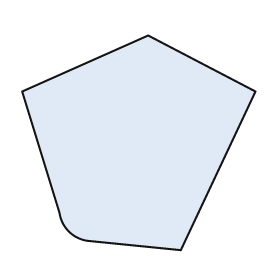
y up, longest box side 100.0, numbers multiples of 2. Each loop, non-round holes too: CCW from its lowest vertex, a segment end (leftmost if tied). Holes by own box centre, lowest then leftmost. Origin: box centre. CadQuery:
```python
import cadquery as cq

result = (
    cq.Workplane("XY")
    .moveTo(18.0, -46.0)
    .lineTo(50.0, 22.0)
    .lineTo(4.0, 46.0)
    .lineTo(-50.0, 22.0)
    .lineTo(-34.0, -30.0)
    .threePointArc((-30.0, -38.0), (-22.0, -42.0))
    .close()
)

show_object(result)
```